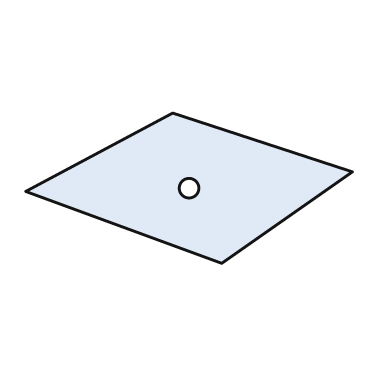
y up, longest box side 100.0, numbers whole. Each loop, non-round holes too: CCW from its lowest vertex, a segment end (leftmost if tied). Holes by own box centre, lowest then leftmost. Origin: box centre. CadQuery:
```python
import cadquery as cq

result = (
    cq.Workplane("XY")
    .moveTo(10.0, -23.0)
    .lineTo(50.0, 5.0)
    .lineTo(-5.0, 23.0)
    .lineTo(-50.0, -1.0)
    .close()
    .moveTo(0.0, 0.0)
    .circle(3.0)
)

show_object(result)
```